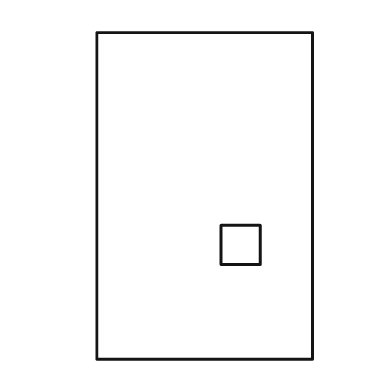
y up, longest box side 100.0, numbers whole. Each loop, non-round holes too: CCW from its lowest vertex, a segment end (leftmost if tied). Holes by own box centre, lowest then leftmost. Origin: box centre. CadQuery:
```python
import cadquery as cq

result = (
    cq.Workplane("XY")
    .moveTo(-33.0, -50.0)
    .lineTo(33.0, -50.0)
    .lineTo(33.0, 50.0)
    .lineTo(-33.0, 50.0)
    .close()
    .moveTo(5.0, -21.0)
    .lineTo(17.0, -21.0)
    .lineTo(17.0, -9.0)
    .lineTo(5.0, -9.0)
    .close()
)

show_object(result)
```